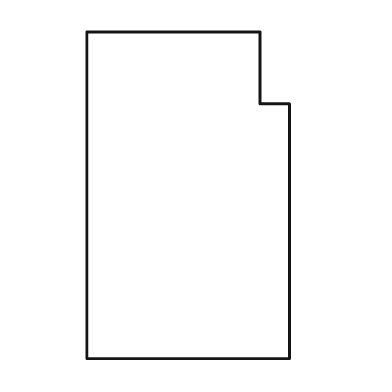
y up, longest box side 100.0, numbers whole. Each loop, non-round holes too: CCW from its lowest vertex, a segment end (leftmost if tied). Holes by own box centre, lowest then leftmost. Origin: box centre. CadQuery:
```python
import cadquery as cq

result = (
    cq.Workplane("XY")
    .moveTo(-31.0, -50.0)
    .lineTo(31.0, -50.0)
    .lineTo(31.0, 28.0)
    .lineTo(22.0, 28.0)
    .lineTo(22.0, 50.0)
    .lineTo(-31.0, 50.0)
    .close()
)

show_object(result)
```